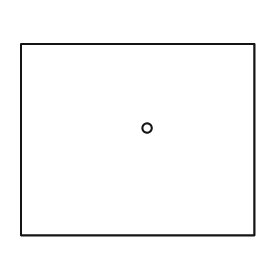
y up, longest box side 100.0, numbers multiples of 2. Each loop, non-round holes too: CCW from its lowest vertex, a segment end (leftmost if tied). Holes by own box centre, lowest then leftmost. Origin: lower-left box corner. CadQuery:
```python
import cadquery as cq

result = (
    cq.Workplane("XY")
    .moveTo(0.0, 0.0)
    .lineTo(100.0, 0.0)
    .lineTo(100.0, 82.0)
    .lineTo(0.0, 82.0)
    .close()
    .moveTo(54.0, 46.0)
    .circle(2.0)
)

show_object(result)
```